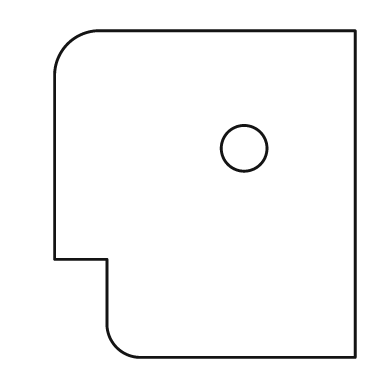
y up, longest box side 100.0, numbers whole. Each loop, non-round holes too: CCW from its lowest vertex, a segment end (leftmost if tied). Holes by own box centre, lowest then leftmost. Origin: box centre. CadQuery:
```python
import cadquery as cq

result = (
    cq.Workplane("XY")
    .moveTo(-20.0, -50.0)
    .lineTo(46.0, -50.0)
    .lineTo(46.0, 50.0)
    .lineTo(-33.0, 50.0)
    .threePointArc((-42.0, 46.0), (-46.0, 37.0))
    .lineTo(-46.0, -20.0)
    .lineTo(-30.0, -20.0)
    .lineTo(-30.0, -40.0)
    .threePointArc((-27.0, -47.0), (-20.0, -50.0))
    .close()
    .moveTo(12.0, 14.0)
    .circle(7.0)
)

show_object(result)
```